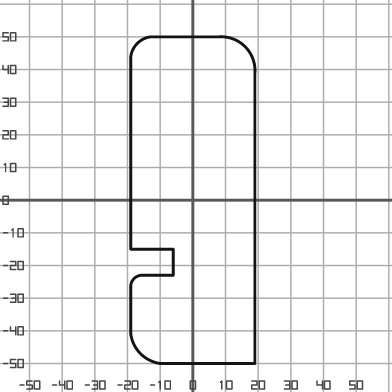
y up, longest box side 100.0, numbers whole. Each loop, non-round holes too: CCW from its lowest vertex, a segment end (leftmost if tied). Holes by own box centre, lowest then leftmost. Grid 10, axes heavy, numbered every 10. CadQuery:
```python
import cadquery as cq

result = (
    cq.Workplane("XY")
    .moveTo(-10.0, -50.0)
    .lineTo(19.0, -50.0)
    .lineTo(19.0, 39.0)
    .threePointArc((16.0, 47.0), (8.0, 50.0))
    .lineTo(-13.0, 50.0)
    .threePointArc((-17.0, 48.0), (-19.0, 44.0))
    .lineTo(-19.0, -15.0)
    .lineTo(-6.0, -15.0)
    .lineTo(-6.0, -23.0)
    .lineTo(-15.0, -23.0)
    .threePointArc((-18.0, -24.0), (-19.0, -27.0))
    .lineTo(-19.0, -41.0)
    .threePointArc((-16.0, -47.0), (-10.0, -50.0))
    .close()
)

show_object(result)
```